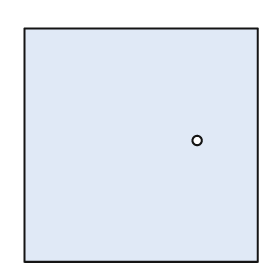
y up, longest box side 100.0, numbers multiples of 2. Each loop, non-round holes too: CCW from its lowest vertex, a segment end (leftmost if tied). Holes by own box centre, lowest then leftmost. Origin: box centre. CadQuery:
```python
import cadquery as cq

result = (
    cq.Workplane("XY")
    .moveTo(-50.0, -50.0)
    .lineTo(50.0, -50.0)
    .lineTo(50.0, 50.0)
    .lineTo(-50.0, 50.0)
    .close()
    .moveTo(24.0, 2.0)
    .circle(2.0)
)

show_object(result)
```